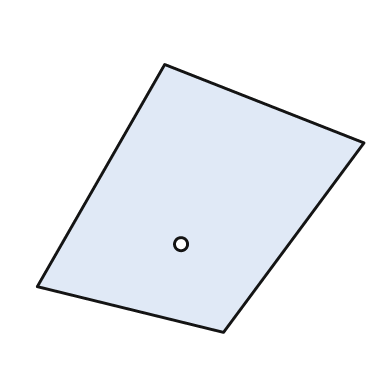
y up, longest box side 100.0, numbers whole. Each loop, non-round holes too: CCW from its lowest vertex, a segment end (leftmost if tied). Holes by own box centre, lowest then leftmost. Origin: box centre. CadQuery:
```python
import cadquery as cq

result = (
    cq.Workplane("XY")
    .moveTo(7.0, -41.0)
    .lineTo(50.0, 17.0)
    .lineTo(-11.0, 41.0)
    .lineTo(-50.0, -27.0)
    .close()
    .moveTo(-6.0, -14.0)
    .circle(2.0)
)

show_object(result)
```